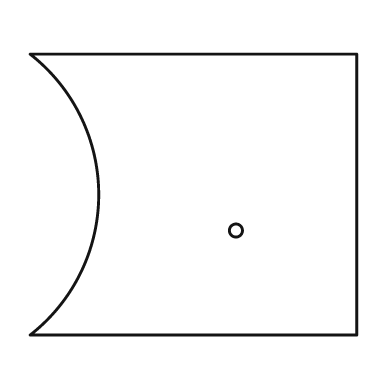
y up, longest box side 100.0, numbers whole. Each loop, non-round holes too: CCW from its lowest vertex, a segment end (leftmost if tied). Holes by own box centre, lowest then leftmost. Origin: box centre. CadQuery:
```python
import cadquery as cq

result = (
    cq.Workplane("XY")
    .moveTo(-50.0, -43.0)
    .lineTo(50.0, -43.0)
    .lineTo(50.0, 43.0)
    .lineTo(-50.0, 43.0)
    .threePointArc((-29.0, 0.0), (-50.0, -43.0))
    .close()
    .moveTo(13.0, -11.0)
    .circle(2.0)
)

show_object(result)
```